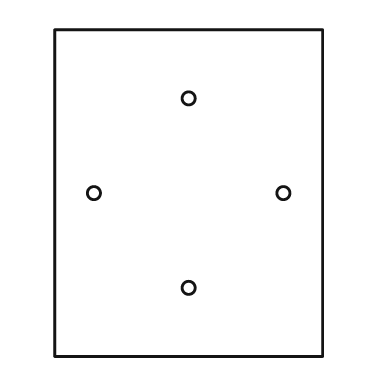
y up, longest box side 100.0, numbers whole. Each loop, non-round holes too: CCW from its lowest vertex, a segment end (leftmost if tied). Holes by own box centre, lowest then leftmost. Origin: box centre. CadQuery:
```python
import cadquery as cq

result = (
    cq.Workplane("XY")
    .moveTo(-41.0, -50.0)
    .lineTo(41.0, -50.0)
    .lineTo(41.0, 50.0)
    .lineTo(-41.0, 50.0)
    .close()
    .moveTo(0.0, -29.0)
    .circle(2.0)
    .moveTo(-29.0, 0.0)
    .circle(2.0)
    .moveTo(29.0, 0.0)
    .circle(2.0)
    .moveTo(0.0, 29.0)
    .circle(2.0)
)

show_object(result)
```